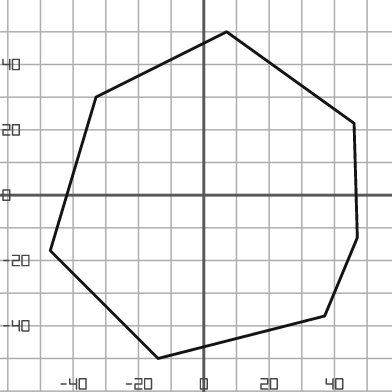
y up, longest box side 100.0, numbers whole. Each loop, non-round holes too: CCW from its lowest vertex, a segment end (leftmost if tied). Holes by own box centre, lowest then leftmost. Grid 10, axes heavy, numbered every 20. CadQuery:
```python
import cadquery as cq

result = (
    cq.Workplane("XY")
    .moveTo(-14.0, -50.0)
    .lineTo(37.0, -37.0)
    .lineTo(47.0, -13.0)
    .lineTo(46.0, 22.0)
    .lineTo(7.0, 50.0)
    .lineTo(-33.0, 30.0)
    .lineTo(-47.0, -17.0)
    .close()
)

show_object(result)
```